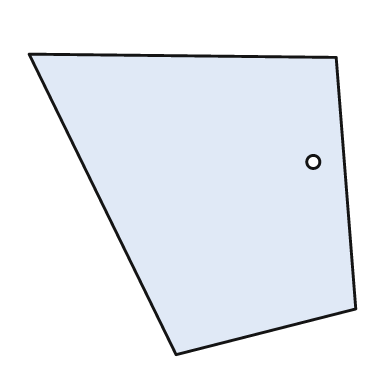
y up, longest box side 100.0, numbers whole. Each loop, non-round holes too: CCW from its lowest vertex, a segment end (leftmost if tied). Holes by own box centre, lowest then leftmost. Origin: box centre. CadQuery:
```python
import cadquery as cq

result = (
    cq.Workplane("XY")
    .moveTo(-5.0, -46.0)
    .lineTo(50.0, -32.0)
    .lineTo(44.0, 45.0)
    .lineTo(-50.0, 46.0)
    .close()
    .moveTo(37.0, 13.0)
    .circle(2.0)
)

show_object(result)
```